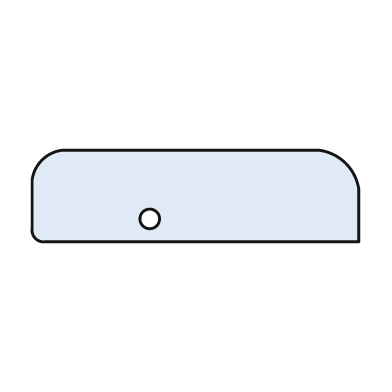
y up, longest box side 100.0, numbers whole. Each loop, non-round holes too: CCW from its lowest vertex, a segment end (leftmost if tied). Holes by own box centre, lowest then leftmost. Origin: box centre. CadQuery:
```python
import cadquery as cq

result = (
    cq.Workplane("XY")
    .moveTo(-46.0, -14.0)
    .lineTo(50.0, -14.0)
    .lineTo(50.0, 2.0)
    .threePointArc((46.0, 10.0), (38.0, 14.0))
    .lineTo(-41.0, 14.0)
    .threePointArc((-47.0, 11.0), (-50.0, 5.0))
    .lineTo(-50.0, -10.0)
    .threePointArc((-49.0, -13.0), (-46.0, -14.0))
    .close()
    .moveTo(-14.0, -7.0)
    .circle(3.0)
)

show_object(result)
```